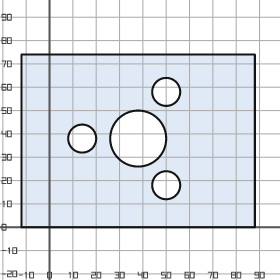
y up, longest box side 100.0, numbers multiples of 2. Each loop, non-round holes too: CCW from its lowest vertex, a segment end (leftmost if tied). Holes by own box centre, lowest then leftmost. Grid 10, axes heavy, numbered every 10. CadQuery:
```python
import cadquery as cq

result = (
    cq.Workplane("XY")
    .moveTo(-12.0, 0.0)
    .lineTo(88.0, 0.0)
    .lineTo(88.0, 74.0)
    .lineTo(-12.0, 74.0)
    .close()
    .moveTo(50.0, 18.0)
    .circle(6.0)
    .moveTo(14.0, 38.0)
    .circle(6.0)
    .moveTo(38.0, 38.0)
    .circle(12.0)
    .moveTo(50.0, 58.0)
    .circle(6.0)
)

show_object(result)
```